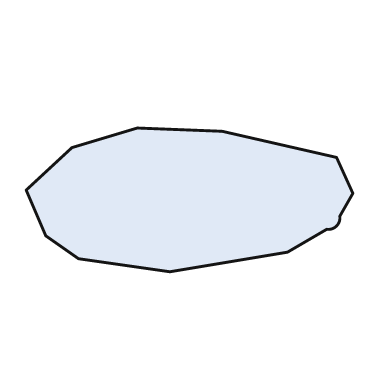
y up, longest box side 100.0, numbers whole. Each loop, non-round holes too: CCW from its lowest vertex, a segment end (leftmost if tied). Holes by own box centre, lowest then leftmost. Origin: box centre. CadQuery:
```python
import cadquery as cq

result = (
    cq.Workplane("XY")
    .moveTo(-6.0, -22.0)
    .lineTo(30.0, -16.0)
    .lineTo(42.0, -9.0)
    .threePointArc((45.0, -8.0), (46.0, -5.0))
    .lineTo(50.0, 2.0)
    .lineTo(45.0, 13.0)
    .lineTo(10.0, 21.0)
    .lineTo(-16.0, 22.0)
    .lineTo(-36.0, 16.0)
    .lineTo(-50.0, 3.0)
    .lineTo(-44.0, -11.0)
    .lineTo(-34.0, -18.0)
    .close()
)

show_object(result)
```